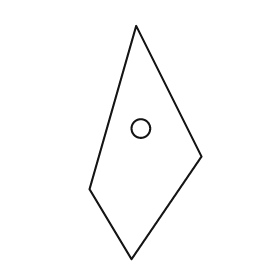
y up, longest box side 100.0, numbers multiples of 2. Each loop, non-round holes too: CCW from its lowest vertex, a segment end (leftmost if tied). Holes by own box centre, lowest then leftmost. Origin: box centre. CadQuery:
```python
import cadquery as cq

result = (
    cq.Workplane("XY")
    .moveTo(-6.0, -50.0)
    .lineTo(24.0, -6.0)
    .lineTo(-4.0, 50.0)
    .lineTo(-24.0, -20.0)
    .close()
    .moveTo(-2.0, 6.0)
    .circle(4.0)
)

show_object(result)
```